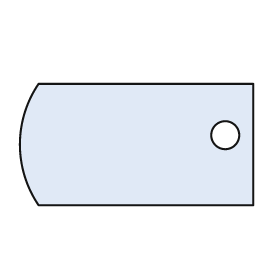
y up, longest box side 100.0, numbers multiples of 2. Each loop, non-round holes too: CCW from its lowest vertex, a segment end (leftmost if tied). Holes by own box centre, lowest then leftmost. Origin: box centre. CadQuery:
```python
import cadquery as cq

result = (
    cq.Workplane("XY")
    .moveTo(-42.0, -26.0)
    .lineTo(50.0, -26.0)
    .lineTo(50.0, 26.0)
    .lineTo(-42.0, 26.0)
    .threePointArc((-50.0, 0.0), (-42.0, -26.0))
    .close()
    .moveTo(38.0, 4.0)
    .circle(6.0)
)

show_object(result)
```